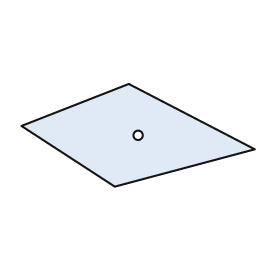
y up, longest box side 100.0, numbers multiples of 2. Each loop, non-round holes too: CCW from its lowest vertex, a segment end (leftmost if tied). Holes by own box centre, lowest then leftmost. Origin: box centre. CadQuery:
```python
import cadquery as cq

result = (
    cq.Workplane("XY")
    .moveTo(-10.0, -22.0)
    .lineTo(50.0, -6.0)
    .lineTo(-4.0, 22.0)
    .lineTo(-50.0, 4.0)
    .close()
    .moveTo(0.0, 0.0)
    .circle(2.0)
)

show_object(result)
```